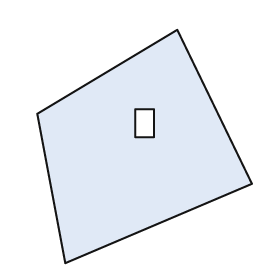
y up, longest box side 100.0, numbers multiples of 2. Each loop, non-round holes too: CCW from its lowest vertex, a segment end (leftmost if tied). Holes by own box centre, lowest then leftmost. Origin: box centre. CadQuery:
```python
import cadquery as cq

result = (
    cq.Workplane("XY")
    .moveTo(-34.0, -50.0)
    .lineTo(46.0, -16.0)
    .lineTo(14.0, 50.0)
    .lineTo(-46.0, 14.0)
    .close()
    .moveTo(-4.0, 4.0)
    .lineTo(4.0, 4.0)
    .lineTo(4.0, 16.0)
    .lineTo(-4.0, 16.0)
    .close()
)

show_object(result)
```